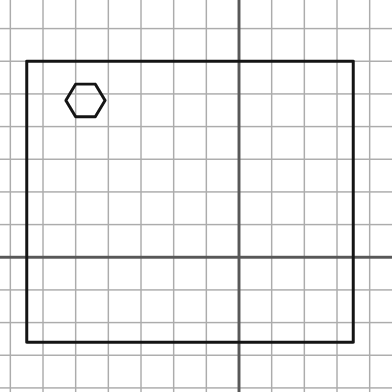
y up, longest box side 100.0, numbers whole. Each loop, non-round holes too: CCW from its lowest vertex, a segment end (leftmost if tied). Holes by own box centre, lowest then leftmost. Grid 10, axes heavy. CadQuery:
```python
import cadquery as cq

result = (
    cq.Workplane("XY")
    .moveTo(-65.0, -26.0)
    .lineTo(35.0, -26.0)
    .lineTo(35.0, 60.0)
    .lineTo(-65.0, 60.0)
    .close()
    .moveTo(-50.0, 43.0)
    .lineTo(-44.0, 43.0)
    .lineTo(-41.0, 48.0)
    .lineTo(-44.0, 53.0)
    .lineTo(-50.0, 53.0)
    .lineTo(-53.0, 48.0)
    .close()
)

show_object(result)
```